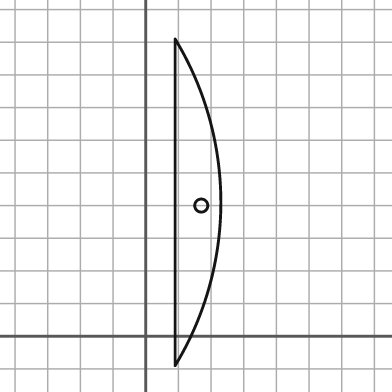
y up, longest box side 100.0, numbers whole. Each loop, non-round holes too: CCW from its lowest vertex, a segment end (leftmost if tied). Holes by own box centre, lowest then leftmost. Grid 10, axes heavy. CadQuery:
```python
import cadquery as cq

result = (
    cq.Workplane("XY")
    .moveTo(9.0, -9.0)
    .threePointArc((23.0, 41.0), (9.0, 91.0))
    .close()
    .moveTo(17.0, 40.0)
    .circle(2.0)
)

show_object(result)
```